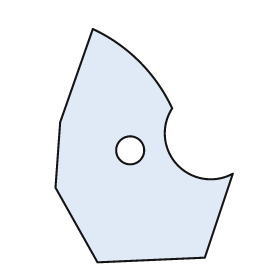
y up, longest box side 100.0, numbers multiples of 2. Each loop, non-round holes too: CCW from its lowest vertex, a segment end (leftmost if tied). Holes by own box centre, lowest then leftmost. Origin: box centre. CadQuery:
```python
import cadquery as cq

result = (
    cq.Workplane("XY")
    .moveTo(-20.0, -50.0)
    .lineTo(26.0, -48.0)
    .lineTo(38.0, -12.0)
    .threePointArc((14.0, -8.0), (12.0, 16.0))
    .threePointArc((-2.0, 36.0), (-22.0, 50.0))
    .lineTo(-36.0, 10.0)
    .lineTo(-38.0, -18.0)
    .close()
    .moveTo(-6.0, -2.0)
    .circle(6.0)
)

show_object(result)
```